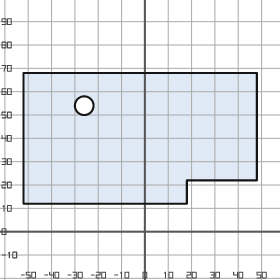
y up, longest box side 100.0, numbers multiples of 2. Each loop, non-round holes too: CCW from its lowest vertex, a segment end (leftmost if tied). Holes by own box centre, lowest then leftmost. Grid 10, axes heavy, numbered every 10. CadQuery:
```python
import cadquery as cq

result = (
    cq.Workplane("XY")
    .moveTo(-52.0, 12.0)
    .lineTo(18.0, 12.0)
    .lineTo(18.0, 22.0)
    .lineTo(48.0, 22.0)
    .lineTo(48.0, 68.0)
    .lineTo(-52.0, 68.0)
    .close()
    .moveTo(-26.0, 54.0)
    .circle(4.0)
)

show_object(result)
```